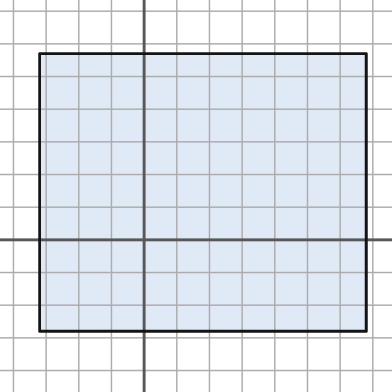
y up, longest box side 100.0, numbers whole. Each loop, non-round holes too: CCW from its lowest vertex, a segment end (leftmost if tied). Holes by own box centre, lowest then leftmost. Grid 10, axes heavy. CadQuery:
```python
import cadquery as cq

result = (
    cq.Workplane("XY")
    .moveTo(-32.0, -28.0)
    .lineTo(68.0, -28.0)
    .lineTo(68.0, 57.0)
    .lineTo(-32.0, 57.0)
    .close()
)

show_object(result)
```